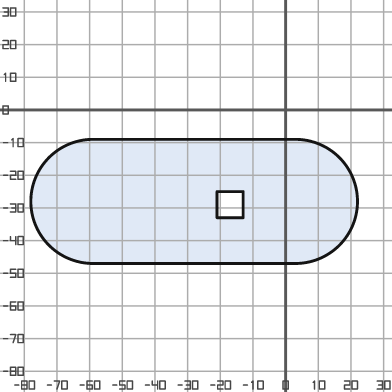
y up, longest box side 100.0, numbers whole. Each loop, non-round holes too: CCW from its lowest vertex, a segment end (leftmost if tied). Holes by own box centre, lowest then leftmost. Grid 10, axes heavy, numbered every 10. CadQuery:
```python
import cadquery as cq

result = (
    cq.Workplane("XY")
    .moveTo(-59.0, -47.0)
    .lineTo(3.0, -47.0)
    .threePointArc((22.0, -28.0), (3.0, -9.0))
    .lineTo(-59.0, -9.0)
    .threePointArc((-78.0, -28.0), (-59.0, -47.0))
    .close()
    .moveTo(-21.0, -33.0)
    .lineTo(-13.0, -33.0)
    .lineTo(-13.0, -25.0)
    .lineTo(-21.0, -25.0)
    .close()
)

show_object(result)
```